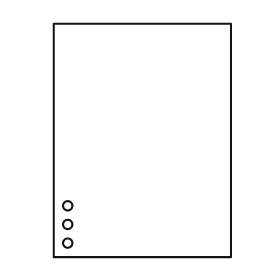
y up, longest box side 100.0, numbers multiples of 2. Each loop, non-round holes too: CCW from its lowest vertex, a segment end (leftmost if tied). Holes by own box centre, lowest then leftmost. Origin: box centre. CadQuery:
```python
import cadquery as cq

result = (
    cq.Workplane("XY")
    .moveTo(-38.0, -50.0)
    .lineTo(38.0, -50.0)
    .lineTo(38.0, 50.0)
    .lineTo(-38.0, 50.0)
    .close()
    .moveTo(-32.0, -44.0)
    .circle(2.0)
    .moveTo(-32.0, -36.0)
    .circle(2.0)
    .moveTo(-32.0, -28.0)
    .circle(2.0)
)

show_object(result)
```